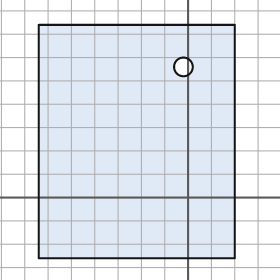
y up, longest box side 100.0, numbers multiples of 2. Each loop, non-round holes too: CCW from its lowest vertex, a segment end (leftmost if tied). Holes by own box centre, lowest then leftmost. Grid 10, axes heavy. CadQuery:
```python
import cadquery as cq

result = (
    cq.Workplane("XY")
    .moveTo(-64.0, -26.0)
    .lineTo(20.0, -26.0)
    .lineTo(20.0, 74.0)
    .lineTo(-64.0, 74.0)
    .close()
    .moveTo(-2.0, 56.0)
    .circle(4.0)
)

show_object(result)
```